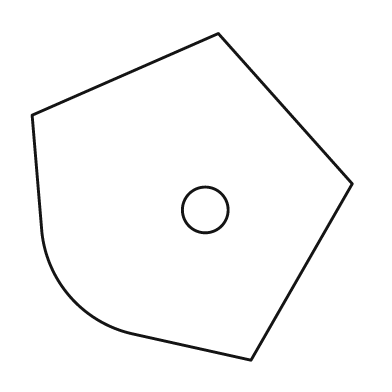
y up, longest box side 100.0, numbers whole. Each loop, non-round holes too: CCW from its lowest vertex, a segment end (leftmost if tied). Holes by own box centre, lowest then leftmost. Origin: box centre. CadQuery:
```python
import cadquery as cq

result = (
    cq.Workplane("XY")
    .moveTo(18.0, -50.0)
    .lineTo(49.0, 4.0)
    .lineTo(8.0, 50.0)
    .lineTo(-49.0, 25.0)
    .lineTo(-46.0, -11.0)
    .threePointArc((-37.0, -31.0), (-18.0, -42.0))
    .close()
    .moveTo(4.0, -4.0)
    .circle(7.0)
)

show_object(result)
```